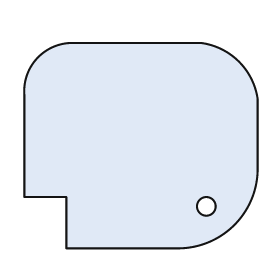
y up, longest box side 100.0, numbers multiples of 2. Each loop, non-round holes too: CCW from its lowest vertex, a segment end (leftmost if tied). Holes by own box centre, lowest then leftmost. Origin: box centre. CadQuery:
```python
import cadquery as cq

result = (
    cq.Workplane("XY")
    .moveTo(-32.0, -44.0)
    .lineTo(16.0, -44.0)
    .threePointArc((40.0, -34.0), (50.0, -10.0))
    .lineTo(50.0, 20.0)
    .threePointArc((42.0, 36.0), (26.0, 44.0))
    .lineTo(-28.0, 44.0)
    .threePointArc((-44.0, 38.0), (-50.0, 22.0))
    .lineTo(-50.0, -22.0)
    .lineTo(-32.0, -22.0)
    .close()
    .moveTo(28.0, -26.0)
    .circle(4.0)
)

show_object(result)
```